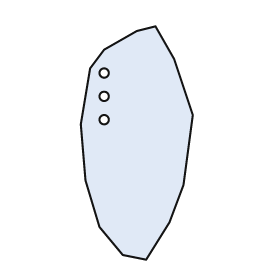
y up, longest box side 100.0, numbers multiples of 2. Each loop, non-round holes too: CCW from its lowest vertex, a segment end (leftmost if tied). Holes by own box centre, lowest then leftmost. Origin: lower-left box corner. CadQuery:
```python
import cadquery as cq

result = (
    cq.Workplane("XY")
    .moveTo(28.0, 0.0)
    .lineTo(38.0, 16.0)
    .lineTo(44.0, 32.0)
    .lineTo(48.0, 62.0)
    .lineTo(40.0, 86.0)
    .lineTo(32.0, 100.0)
    .lineTo(24.0, 98.0)
    .lineTo(10.0, 90.0)
    .lineTo(4.0, 82.0)
    .lineTo(0.0, 58.0)
    .lineTo(2.0, 34.0)
    .lineTo(8.0, 14.0)
    .lineTo(18.0, 2.0)
    .close()
    .moveTo(10.0, 60.0)
    .circle(2.0)
    .moveTo(10.0, 70.0)
    .circle(2.0)
    .moveTo(10.0, 80.0)
    .circle(2.0)
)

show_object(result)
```